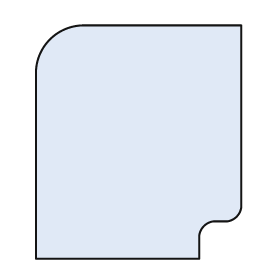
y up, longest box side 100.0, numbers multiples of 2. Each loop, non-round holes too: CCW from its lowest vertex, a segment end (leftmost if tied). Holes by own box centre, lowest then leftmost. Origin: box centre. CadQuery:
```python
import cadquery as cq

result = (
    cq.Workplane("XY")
    .moveTo(-44.0, -50.0)
    .lineTo(26.0, -50.0)
    .lineTo(26.0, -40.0)
    .threePointArc((28.0, -36.0), (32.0, -34.0))
    .lineTo(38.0, -34.0)
    .threePointArc((42.0, -32.0), (44.0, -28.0))
    .lineTo(44.0, 50.0)
    .lineTo(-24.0, 50.0)
    .threePointArc((-38.0, 44.0), (-44.0, 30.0))
    .close()
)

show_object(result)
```